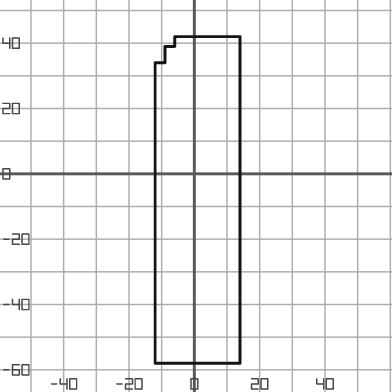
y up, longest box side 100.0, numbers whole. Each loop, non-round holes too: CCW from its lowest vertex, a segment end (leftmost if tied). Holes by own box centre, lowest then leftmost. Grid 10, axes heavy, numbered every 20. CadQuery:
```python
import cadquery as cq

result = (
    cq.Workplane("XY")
    .moveTo(-12.0, -58.0)
    .lineTo(14.0, -58.0)
    .lineTo(14.0, 42.0)
    .lineTo(-6.0, 42.0)
    .lineTo(-6.0, 39.0)
    .lineTo(-9.0, 39.0)
    .lineTo(-9.0, 34.0)
    .lineTo(-12.0, 34.0)
    .close()
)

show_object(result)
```